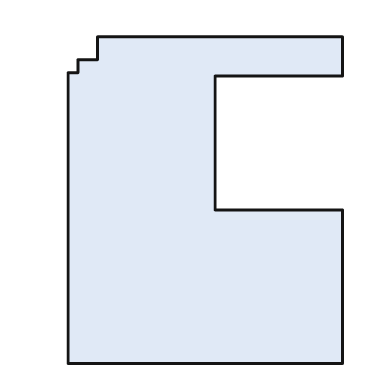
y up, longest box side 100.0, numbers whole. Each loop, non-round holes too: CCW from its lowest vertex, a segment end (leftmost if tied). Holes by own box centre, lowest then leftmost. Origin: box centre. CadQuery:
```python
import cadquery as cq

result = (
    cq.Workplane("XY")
    .moveTo(-42.0, -50.0)
    .lineTo(42.0, -50.0)
    .lineTo(42.0, -3.0)
    .lineTo(3.0, -3.0)
    .lineTo(3.0, 38.0)
    .lineTo(42.0, 38.0)
    .lineTo(42.0, 50.0)
    .lineTo(-33.0, 50.0)
    .lineTo(-33.0, 43.0)
    .lineTo(-39.0, 43.0)
    .lineTo(-39.0, 39.0)
    .lineTo(-42.0, 39.0)
    .close()
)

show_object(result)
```